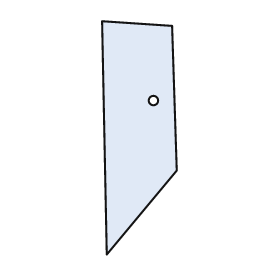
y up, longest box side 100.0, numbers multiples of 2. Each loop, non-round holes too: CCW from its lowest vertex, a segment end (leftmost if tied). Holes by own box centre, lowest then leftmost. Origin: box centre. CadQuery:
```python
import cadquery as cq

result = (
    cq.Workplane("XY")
    .moveTo(-14.0, -50.0)
    .lineTo(16.0, -14.0)
    .lineTo(14.0, 48.0)
    .lineTo(-16.0, 50.0)
    .close()
    .moveTo(6.0, 16.0)
    .circle(2.0)
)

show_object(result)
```